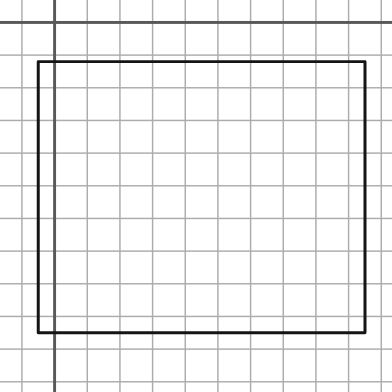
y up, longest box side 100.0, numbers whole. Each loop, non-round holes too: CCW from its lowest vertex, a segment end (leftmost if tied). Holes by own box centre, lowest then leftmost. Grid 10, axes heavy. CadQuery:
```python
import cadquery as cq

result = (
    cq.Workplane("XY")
    .moveTo(-5.0, -95.0)
    .lineTo(95.0, -95.0)
    .lineTo(95.0, -12.0)
    .lineTo(-5.0, -12.0)
    .close()
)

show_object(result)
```